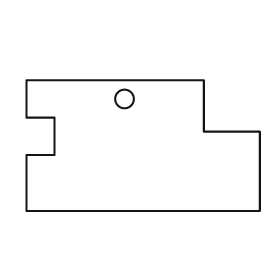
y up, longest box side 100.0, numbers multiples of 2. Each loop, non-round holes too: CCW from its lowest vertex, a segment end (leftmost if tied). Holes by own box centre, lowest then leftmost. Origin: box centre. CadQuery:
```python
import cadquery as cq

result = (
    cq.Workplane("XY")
    .moveTo(-50.0, -28.0)
    .lineTo(50.0, -28.0)
    .lineTo(50.0, 6.0)
    .lineTo(26.0, 6.0)
    .lineTo(26.0, 28.0)
    .lineTo(-50.0, 28.0)
    .lineTo(-50.0, 12.0)
    .lineTo(-38.0, 12.0)
    .lineTo(-38.0, -4.0)
    .lineTo(-50.0, -4.0)
    .close()
    .moveTo(-8.0, 20.0)
    .circle(4.0)
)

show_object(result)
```